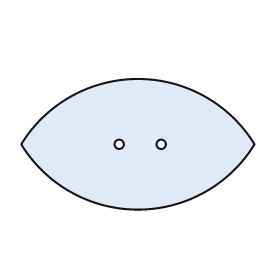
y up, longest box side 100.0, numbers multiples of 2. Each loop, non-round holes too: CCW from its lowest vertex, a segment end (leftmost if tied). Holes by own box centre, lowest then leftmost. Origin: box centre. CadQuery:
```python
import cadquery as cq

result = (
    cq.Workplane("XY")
    .moveTo(-50.0, 0.0)
    .threePointArc((0.0, -28.0), (50.0, 0.0))
    .threePointArc((0.0, 28.0), (-50.0, 0.0))
    .close()
    .moveTo(-8.0, 0.0)
    .circle(2.0)
    .moveTo(10.0, 0.0)
    .circle(2.0)
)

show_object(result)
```